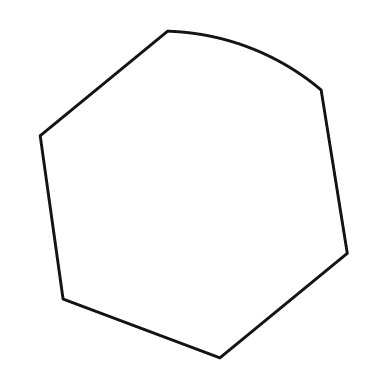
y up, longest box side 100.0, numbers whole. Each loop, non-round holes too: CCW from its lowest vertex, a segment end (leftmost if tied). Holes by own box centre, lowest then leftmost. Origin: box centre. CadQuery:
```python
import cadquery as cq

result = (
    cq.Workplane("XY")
    .moveTo(8.0, -50.0)
    .lineTo(47.0, -18.0)
    .lineTo(39.0, 32.0)
    .threePointArc((17.0, 45.0), (-8.0, 50.0))
    .lineTo(-47.0, 18.0)
    .lineTo(-40.0, -32.0)
    .close()
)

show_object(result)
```